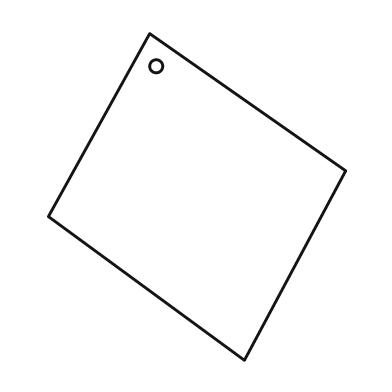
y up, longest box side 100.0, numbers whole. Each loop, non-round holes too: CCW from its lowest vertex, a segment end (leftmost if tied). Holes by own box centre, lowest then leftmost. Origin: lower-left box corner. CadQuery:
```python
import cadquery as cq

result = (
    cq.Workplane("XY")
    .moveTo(60.0, 0.0)
    .lineTo(91.0, 58.0)
    .lineTo(31.0, 100.0)
    .lineTo(0.0, 44.0)
    .close()
    .moveTo(33.0, 90.0)
    .circle(2.0)
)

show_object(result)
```